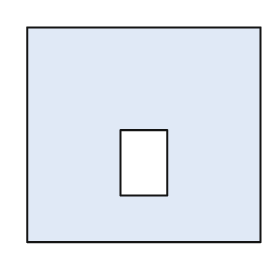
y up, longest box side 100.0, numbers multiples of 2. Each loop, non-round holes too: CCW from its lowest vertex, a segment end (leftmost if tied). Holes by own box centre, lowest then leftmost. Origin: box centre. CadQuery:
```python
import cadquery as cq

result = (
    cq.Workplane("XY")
    .moveTo(-50.0, -46.0)
    .lineTo(50.0, -46.0)
    .lineTo(50.0, 46.0)
    .lineTo(-50.0, 46.0)
    .close()
    .moveTo(-10.0, -26.0)
    .lineTo(10.0, -26.0)
    .lineTo(10.0, 2.0)
    .lineTo(-10.0, 2.0)
    .close()
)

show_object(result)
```